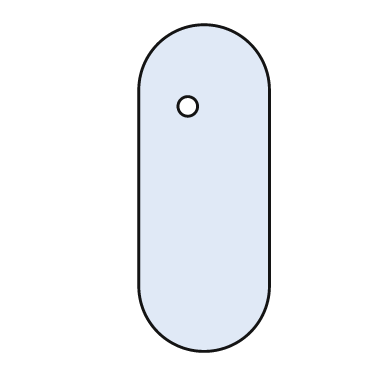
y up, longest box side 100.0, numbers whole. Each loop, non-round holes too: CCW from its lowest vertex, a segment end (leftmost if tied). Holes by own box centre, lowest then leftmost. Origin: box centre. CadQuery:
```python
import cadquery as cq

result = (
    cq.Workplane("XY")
    .moveTo(-20.0, -30.0)
    .threePointArc((0.0, -50.0), (20.0, -30.0))
    .lineTo(20.0, 30.0)
    .threePointArc((0.0, 50.0), (-20.0, 30.0))
    .close()
    .moveTo(-5.0, 25.0)
    .circle(3.0)
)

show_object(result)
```